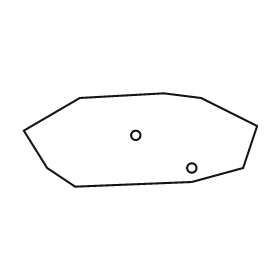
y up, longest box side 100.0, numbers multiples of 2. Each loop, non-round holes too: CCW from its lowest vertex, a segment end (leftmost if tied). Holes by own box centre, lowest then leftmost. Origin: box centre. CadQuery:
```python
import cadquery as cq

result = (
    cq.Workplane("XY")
    .moveTo(-28.0, -20.0)
    .lineTo(22.0, -18.0)
    .lineTo(44.0, -12.0)
    .lineTo(50.0, 6.0)
    .lineTo(26.0, 18.0)
    .lineTo(10.0, 20.0)
    .lineTo(-26.0, 18.0)
    .lineTo(-50.0, 4.0)
    .lineTo(-40.0, -12.0)
    .close()
    .moveTo(22.0, -12.0)
    .circle(2.0)
    .moveTo(-2.0, 2.0)
    .circle(2.0)
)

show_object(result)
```